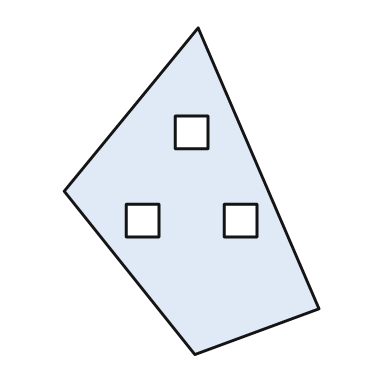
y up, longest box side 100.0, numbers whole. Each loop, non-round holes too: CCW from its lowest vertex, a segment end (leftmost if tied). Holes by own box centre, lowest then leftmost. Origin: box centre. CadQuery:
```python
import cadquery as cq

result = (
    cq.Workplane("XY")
    .moveTo(1.0, -50.0)
    .lineTo(39.0, -36.0)
    .lineTo(2.0, 50.0)
    .lineTo(-39.0, 0.0)
    .close()
    .moveTo(-20.0, -14.0)
    .lineTo(-10.0, -14.0)
    .lineTo(-10.0, -4.0)
    .lineTo(-20.0, -4.0)
    .close()
    .moveTo(10.0, -14.0)
    .lineTo(20.0, -14.0)
    .lineTo(20.0, -4.0)
    .lineTo(10.0, -4.0)
    .close()
    .moveTo(-5.0, 13.0)
    .lineTo(5.0, 13.0)
    .lineTo(5.0, 23.0)
    .lineTo(-5.0, 23.0)
    .close()
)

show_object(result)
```